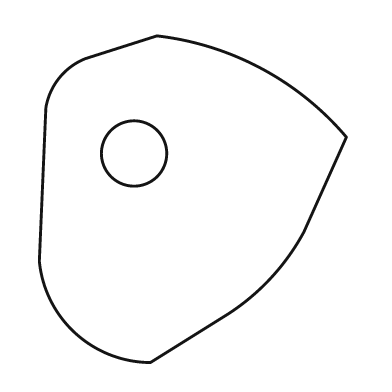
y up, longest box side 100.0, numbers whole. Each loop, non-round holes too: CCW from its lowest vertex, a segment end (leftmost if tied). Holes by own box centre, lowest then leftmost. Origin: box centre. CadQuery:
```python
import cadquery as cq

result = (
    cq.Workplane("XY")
    .moveTo(-13.0, -50.0)
    .lineTo(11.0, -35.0)
    .threePointArc((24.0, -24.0), (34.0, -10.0))
    .lineTo(47.0, 19.0)
    .threePointArc((21.0, 40.0), (-11.0, 50.0))
    .lineTo(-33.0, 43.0)
    .threePointArc((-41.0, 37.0), (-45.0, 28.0))
    .lineTo(-47.0, -19.0)
    .threePointArc((-36.0, -41.0), (-13.0, -50.0))
    .close()
    .moveTo(-18.0, 14.0)
    .circle(10.0)
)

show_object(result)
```